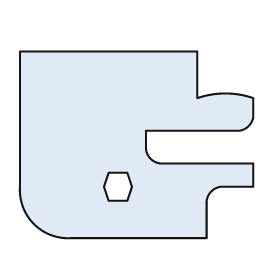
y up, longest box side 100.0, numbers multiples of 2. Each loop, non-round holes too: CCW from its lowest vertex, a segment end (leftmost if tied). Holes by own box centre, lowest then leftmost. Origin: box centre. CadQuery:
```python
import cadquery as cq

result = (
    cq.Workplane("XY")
    .moveTo(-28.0, -40.0)
    .lineTo(30.0, -40.0)
    .lineTo(30.0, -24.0)
    .threePointArc((32.0, -20.0), (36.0, -18.0))
    .lineTo(50.0, -18.0)
    .lineTo(50.0, -8.0)
    .lineTo(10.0, -8.0)
    .threePointArc((6.0, -6.0), (4.0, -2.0))
    .lineTo(4.0, 6.0)
    .lineTo(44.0, 6.0)
    .threePointArc((48.0, 8.0), (50.0, 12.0))
    .lineTo(50.0, 20.0)
    .threePointArc((38.0, 22.0), (26.0, 20.0))
    .lineTo(26.0, 40.0)
    .lineTo(-50.0, 40.0)
    .lineTo(-50.0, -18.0)
    .threePointArc((-44.0, -34.0), (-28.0, -40.0))
    .close()
    .moveTo(-12.0, -24.0)
    .lineTo(-4.0, -24.0)
    .lineTo(-2.0, -18.0)
    .lineTo(-4.0, -12.0)
    .lineTo(-12.0, -12.0)
    .lineTo(-14.0, -18.0)
    .close()
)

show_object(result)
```